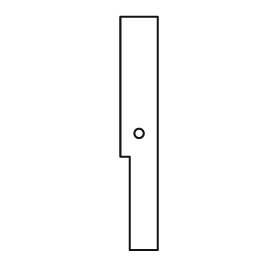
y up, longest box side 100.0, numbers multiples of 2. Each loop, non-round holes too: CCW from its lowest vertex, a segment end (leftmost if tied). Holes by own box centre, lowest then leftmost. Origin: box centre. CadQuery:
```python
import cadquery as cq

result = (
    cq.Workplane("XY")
    .moveTo(-4.0, -50.0)
    .lineTo(8.0, -50.0)
    .lineTo(8.0, 50.0)
    .lineTo(-8.0, 50.0)
    .lineTo(-8.0, -10.0)
    .lineTo(-4.0, -10.0)
    .close()
    .moveTo(0.0, 0.0)
    .circle(2.0)
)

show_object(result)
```